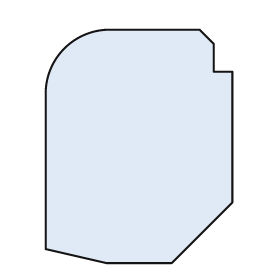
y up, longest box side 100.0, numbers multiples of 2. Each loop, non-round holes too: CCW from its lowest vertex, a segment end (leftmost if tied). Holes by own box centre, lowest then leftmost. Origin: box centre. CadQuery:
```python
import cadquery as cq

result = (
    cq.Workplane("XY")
    .moveTo(-14.0, -50.0)
    .lineTo(14.0, -50.0)
    .lineTo(40.0, -24.0)
    .lineTo(40.0, 32.0)
    .lineTo(32.0, 32.0)
    .lineTo(32.0, 44.0)
    .lineTo(26.0, 50.0)
    .lineTo(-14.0, 50.0)
    .threePointArc((-32.0, 42.0), (-40.0, 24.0))
    .lineTo(-40.0, -44.0)
    .close()
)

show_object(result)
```